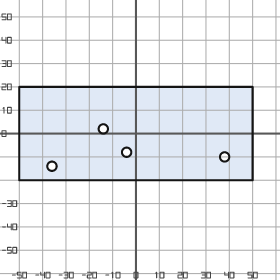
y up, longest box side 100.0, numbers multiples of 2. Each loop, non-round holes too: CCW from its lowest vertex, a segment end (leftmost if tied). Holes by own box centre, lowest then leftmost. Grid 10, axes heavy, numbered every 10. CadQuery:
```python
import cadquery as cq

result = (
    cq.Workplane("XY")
    .moveTo(-50.0, -20.0)
    .lineTo(50.0, -20.0)
    .lineTo(50.0, 20.0)
    .lineTo(-50.0, 20.0)
    .close()
    .moveTo(-36.0, -14.0)
    .circle(2.0)
    .moveTo(38.0, -10.0)
    .circle(2.0)
    .moveTo(-4.0, -8.0)
    .circle(2.0)
    .moveTo(-14.0, 2.0)
    .circle(2.0)
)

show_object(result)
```